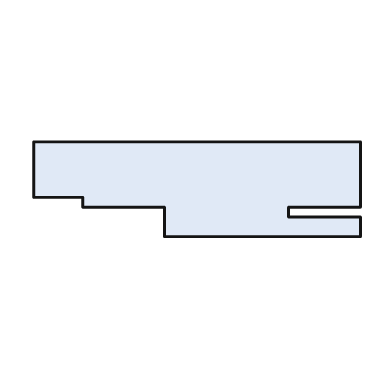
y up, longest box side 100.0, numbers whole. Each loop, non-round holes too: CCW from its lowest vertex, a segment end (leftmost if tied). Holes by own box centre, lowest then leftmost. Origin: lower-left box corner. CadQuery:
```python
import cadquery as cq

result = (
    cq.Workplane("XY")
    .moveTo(40.0, 0.0)
    .lineTo(100.0, 0.0)
    .lineTo(100.0, 6.0)
    .lineTo(78.0, 6.0)
    .lineTo(78.0, 9.0)
    .lineTo(100.0, 9.0)
    .lineTo(100.0, 29.0)
    .lineTo(0.0, 29.0)
    .lineTo(0.0, 12.0)
    .lineTo(15.0, 12.0)
    .lineTo(15.0, 9.0)
    .lineTo(40.0, 9.0)
    .close()
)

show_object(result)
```